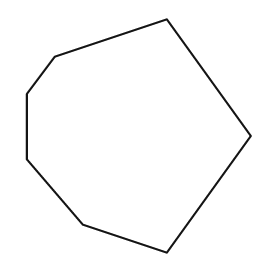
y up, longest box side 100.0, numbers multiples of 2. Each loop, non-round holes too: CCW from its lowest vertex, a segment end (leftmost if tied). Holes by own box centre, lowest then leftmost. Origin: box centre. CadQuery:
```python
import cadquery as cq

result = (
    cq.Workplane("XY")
    .moveTo(12.0, -50.0)
    .lineTo(48.0, 0.0)
    .lineTo(12.0, 50.0)
    .lineTo(-36.0, 34.0)
    .lineTo(-48.0, 18.0)
    .lineTo(-48.0, -10.0)
    .lineTo(-24.0, -38.0)
    .close()
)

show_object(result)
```